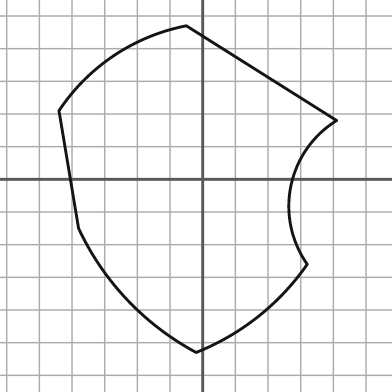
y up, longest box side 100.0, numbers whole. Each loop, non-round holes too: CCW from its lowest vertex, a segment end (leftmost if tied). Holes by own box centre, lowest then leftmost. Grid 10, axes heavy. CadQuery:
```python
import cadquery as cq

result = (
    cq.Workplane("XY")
    .moveTo(-2.0, -53.0)
    .threePointArc((17.0, -42.0), (32.0, -26.0))
    .threePointArc((27.0, -2.0), (41.0, 18.0))
    .lineTo(-5.0, 47.0)
    .threePointArc((-27.0, 38.0), (-44.0, 21.0))
    .lineTo(-38.0, -15.0)
    .threePointArc((-23.0, -37.0), (-2.0, -53.0))
    .close()
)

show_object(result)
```